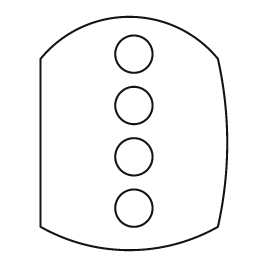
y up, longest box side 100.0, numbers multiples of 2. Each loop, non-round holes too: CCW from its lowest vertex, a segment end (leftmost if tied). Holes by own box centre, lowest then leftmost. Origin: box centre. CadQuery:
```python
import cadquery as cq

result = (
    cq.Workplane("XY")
    .moveTo(-40.0, -40.0)
    .threePointArc((-2.0, -50.0), (36.0, -40.0))
    .threePointArc((40.0, -4.0), (36.0, 32.0))
    .threePointArc((-2.0, 50.0), (-40.0, 32.0))
    .close()
    .moveTo(0.0, -32.0)
    .circle(8.0)
    .moveTo(0.0, -10.0)
    .circle(8.0)
    .moveTo(0.0, 12.0)
    .circle(8.0)
    .moveTo(0.0, 34.0)
    .circle(8.0)
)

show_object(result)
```